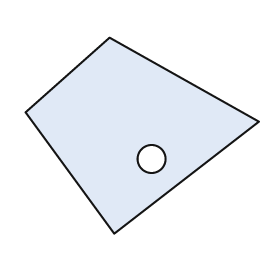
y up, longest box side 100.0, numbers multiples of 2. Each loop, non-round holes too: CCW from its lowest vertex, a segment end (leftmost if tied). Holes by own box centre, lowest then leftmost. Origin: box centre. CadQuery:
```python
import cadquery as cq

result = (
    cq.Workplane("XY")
    .moveTo(-12.0, -42.0)
    .lineTo(50.0, 6.0)
    .lineTo(-14.0, 42.0)
    .lineTo(-50.0, 10.0)
    .close()
    .moveTo(4.0, -10.0)
    .circle(6.0)
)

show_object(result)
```